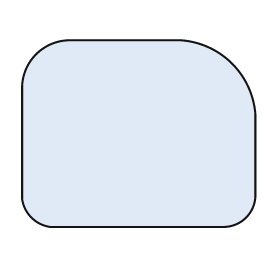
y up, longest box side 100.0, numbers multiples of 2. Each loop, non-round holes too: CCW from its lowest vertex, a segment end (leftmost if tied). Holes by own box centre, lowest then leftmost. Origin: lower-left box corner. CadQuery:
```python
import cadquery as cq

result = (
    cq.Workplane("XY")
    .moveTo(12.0, 0.0)
    .lineTo(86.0, 0.0)
    .threePointArc((96.0, 4.0), (100.0, 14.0))
    .lineTo(100.0, 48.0)
    .threePointArc((90.0, 70.0), (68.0, 80.0))
    .lineTo(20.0, 80.0)
    .threePointArc((6.0, 74.0), (0.0, 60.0))
    .lineTo(0.0, 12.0)
    .threePointArc((4.0, 4.0), (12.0, 0.0))
    .close()
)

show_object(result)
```